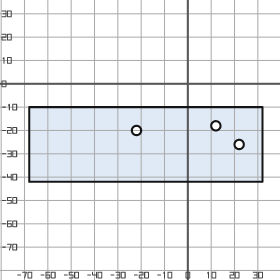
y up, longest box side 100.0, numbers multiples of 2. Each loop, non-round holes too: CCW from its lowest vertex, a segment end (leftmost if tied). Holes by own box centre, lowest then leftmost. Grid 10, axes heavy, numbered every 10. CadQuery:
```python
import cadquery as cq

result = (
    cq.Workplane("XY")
    .moveTo(-68.0, -42.0)
    .lineTo(32.0, -42.0)
    .lineTo(32.0, -10.0)
    .lineTo(-68.0, -10.0)
    .close()
    .moveTo(22.0, -26.0)
    .circle(2.0)
    .moveTo(-22.0, -20.0)
    .circle(2.0)
    .moveTo(12.0, -18.0)
    .circle(2.0)
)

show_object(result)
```